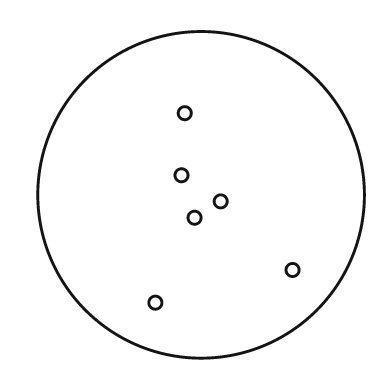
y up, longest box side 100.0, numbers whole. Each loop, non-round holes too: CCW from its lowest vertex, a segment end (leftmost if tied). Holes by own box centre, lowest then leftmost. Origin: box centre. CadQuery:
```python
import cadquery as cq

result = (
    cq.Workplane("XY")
    .moveTo(0.0, 0.0)
    .circle(50.0)
    .moveTo(-14.0, -33.0)
    .circle(2.0)
    .moveTo(28.0, -23.0)
    .circle(2.0)
    .moveTo(-2.0, -7.0)
    .circle(2.0)
    .moveTo(6.0, -2.0)
    .circle(2.0)
    .moveTo(-6.0, 6.0)
    .circle(2.0)
    .moveTo(-5.0, 25.0)
    .circle(2.0)
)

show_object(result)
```